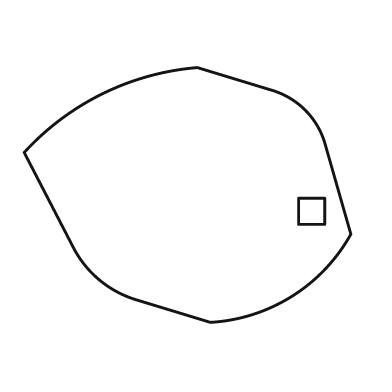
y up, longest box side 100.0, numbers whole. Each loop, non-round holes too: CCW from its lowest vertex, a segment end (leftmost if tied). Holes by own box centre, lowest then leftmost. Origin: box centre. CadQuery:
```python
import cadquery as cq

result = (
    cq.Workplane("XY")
    .moveTo(7.0, -39.0)
    .threePointArc((32.0, -31.0), (50.0, -12.0))
    .lineTo(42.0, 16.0)
    .threePointArc((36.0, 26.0), (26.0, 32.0))
    .lineTo(3.0, 39.0)
    .threePointArc((-26.0, 31.0), (-50.0, 13.0))
    .lineTo(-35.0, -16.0)
    .threePointArc((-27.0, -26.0), (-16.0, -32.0))
    .close()
    .moveTo(34.0, -9.0)
    .lineTo(42.0, -9.0)
    .lineTo(42.0, -1.0)
    .lineTo(34.0, -1.0)
    .close()
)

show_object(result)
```